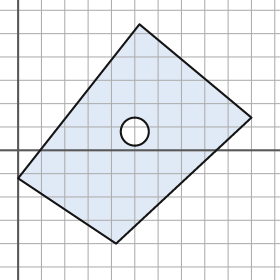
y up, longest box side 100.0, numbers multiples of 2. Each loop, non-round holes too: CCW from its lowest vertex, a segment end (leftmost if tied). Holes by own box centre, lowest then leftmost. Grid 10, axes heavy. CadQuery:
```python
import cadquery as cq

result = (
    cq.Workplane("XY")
    .moveTo(42.0, -40.0)
    .lineTo(100.0, 14.0)
    .lineTo(52.0, 54.0)
    .lineTo(0.0, -12.0)
    .close()
    .moveTo(50.0, 8.0)
    .circle(6.0)
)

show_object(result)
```